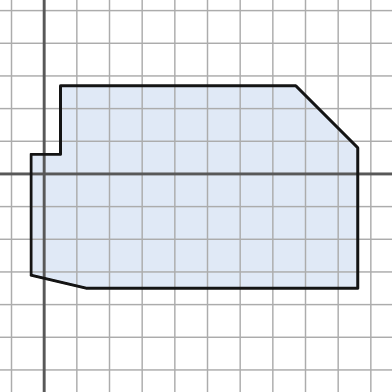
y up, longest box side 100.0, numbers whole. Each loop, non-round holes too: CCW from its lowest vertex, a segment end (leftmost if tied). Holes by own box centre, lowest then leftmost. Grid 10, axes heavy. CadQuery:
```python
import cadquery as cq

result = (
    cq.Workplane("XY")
    .moveTo(13.0, -35.0)
    .lineTo(96.0, -35.0)
    .lineTo(96.0, 8.0)
    .lineTo(77.0, 27.0)
    .lineTo(5.0, 27.0)
    .lineTo(5.0, 6.0)
    .lineTo(-4.0, 6.0)
    .lineTo(-4.0, -31.0)
    .close()
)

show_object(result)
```